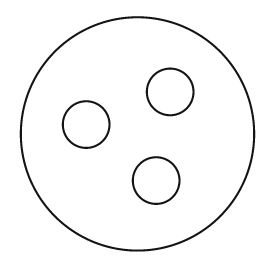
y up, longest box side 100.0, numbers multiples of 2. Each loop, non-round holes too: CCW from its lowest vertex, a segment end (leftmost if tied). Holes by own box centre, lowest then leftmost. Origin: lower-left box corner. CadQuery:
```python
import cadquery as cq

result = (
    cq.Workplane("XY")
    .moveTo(50.0, 50.0)
    .circle(50.0)
    .moveTo(58.0, 30.0)
    .circle(10.0)
    .moveTo(28.0, 54.0)
    .circle(10.0)
    .moveTo(64.0, 68.0)
    .circle(10.0)
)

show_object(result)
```